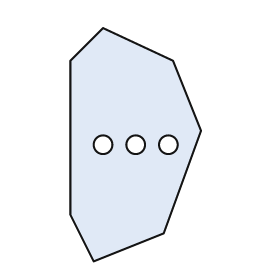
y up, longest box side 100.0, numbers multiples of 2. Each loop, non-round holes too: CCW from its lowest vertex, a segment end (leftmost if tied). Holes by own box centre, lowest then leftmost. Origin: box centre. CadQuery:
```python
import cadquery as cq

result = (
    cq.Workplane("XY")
    .moveTo(-18.0, -50.0)
    .lineTo(12.0, -38.0)
    .lineTo(28.0, 6.0)
    .lineTo(16.0, 36.0)
    .lineTo(-14.0, 50.0)
    .lineTo(-28.0, 36.0)
    .lineTo(-28.0, -30.0)
    .close()
    .moveTo(-14.0, 0.0)
    .circle(4.0)
    .moveTo(0.0, 0.0)
    .circle(4.0)
    .moveTo(14.0, 0.0)
    .circle(4.0)
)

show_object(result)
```